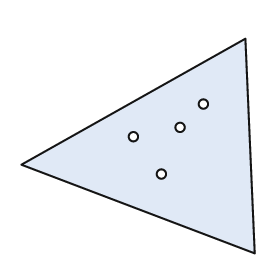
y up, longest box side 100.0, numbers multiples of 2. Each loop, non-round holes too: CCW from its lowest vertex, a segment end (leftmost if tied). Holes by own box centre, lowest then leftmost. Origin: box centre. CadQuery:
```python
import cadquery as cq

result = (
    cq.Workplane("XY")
    .moveTo(50.0, -46.0)
    .lineTo(46.0, 46.0)
    .lineTo(-50.0, -8.0)
    .close()
    .moveTo(10.0, -12.0)
    .circle(2.0)
    .moveTo(-2.0, 4.0)
    .circle(2.0)
    .moveTo(18.0, 8.0)
    .circle(2.0)
    .moveTo(28.0, 18.0)
    .circle(2.0)
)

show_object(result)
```